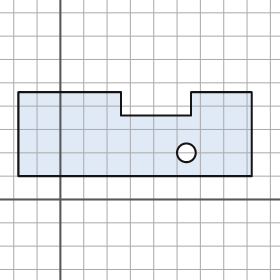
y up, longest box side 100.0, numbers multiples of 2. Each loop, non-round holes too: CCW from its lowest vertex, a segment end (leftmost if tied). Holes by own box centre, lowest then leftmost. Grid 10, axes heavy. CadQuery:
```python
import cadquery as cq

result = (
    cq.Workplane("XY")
    .moveTo(-18.0, 10.0)
    .lineTo(82.0, 10.0)
    .lineTo(82.0, 46.0)
    .lineTo(56.0, 46.0)
    .lineTo(56.0, 36.0)
    .lineTo(26.0, 36.0)
    .lineTo(26.0, 46.0)
    .lineTo(-18.0, 46.0)
    .close()
    .moveTo(54.0, 20.0)
    .circle(4.0)
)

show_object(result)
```